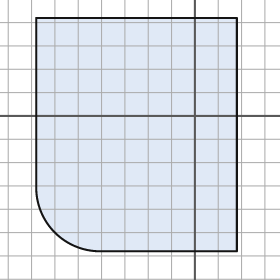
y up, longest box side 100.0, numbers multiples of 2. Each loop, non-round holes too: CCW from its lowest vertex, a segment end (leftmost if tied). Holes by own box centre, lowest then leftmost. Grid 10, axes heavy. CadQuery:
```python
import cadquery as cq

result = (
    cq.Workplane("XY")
    .moveTo(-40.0, -58.0)
    .lineTo(18.0, -58.0)
    .lineTo(18.0, 42.0)
    .lineTo(-68.0, 42.0)
    .lineTo(-68.0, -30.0)
    .threePointArc((-60.0, -50.0), (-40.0, -58.0))
    .close()
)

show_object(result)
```